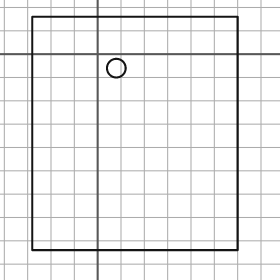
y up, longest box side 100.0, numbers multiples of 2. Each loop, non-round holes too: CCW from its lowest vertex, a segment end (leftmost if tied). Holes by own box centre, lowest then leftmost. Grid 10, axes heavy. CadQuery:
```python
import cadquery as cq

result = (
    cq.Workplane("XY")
    .moveTo(-28.0, -84.0)
    .lineTo(60.0, -84.0)
    .lineTo(60.0, 16.0)
    .lineTo(-28.0, 16.0)
    .close()
    .moveTo(8.0, -6.0)
    .circle(4.0)
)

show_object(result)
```